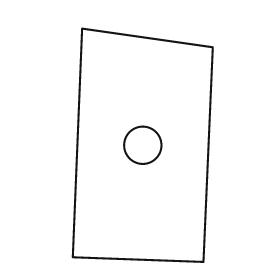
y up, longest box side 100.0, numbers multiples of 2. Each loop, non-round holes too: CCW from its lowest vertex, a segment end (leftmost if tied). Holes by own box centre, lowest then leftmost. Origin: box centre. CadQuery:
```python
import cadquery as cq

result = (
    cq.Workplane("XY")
    .moveTo(26.0, -50.0)
    .lineTo(30.0, 42.0)
    .lineTo(-26.0, 50.0)
    .lineTo(-30.0, -48.0)
    .close()
    .moveTo(0.0, 0.0)
    .circle(8.0)
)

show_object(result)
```